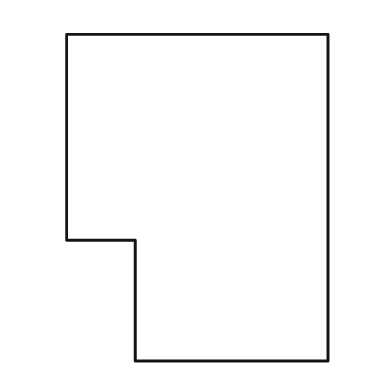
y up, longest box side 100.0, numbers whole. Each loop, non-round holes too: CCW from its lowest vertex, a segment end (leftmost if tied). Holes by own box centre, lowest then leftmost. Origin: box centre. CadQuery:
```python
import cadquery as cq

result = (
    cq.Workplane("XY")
    .moveTo(-19.0, -50.0)
    .lineTo(40.0, -50.0)
    .lineTo(40.0, 50.0)
    .lineTo(-40.0, 50.0)
    .lineTo(-40.0, -13.0)
    .lineTo(-19.0, -13.0)
    .close()
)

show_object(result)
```